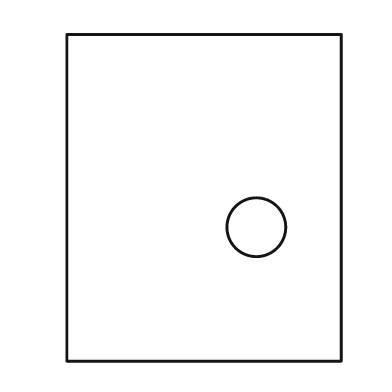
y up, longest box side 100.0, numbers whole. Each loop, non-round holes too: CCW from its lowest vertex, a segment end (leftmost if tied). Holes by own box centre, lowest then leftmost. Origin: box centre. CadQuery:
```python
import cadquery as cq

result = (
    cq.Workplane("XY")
    .moveTo(-42.0, -50.0)
    .lineTo(42.0, -50.0)
    .lineTo(42.0, 50.0)
    .lineTo(-42.0, 50.0)
    .close()
    .moveTo(16.0, -9.0)
    .circle(9.0)
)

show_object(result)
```